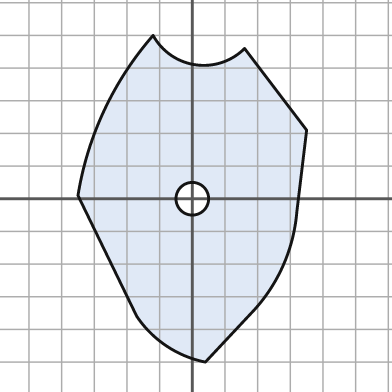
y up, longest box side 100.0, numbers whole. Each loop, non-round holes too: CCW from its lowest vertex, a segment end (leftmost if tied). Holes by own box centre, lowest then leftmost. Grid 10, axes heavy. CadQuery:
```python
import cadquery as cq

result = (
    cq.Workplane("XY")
    .moveTo(4.0, -50.0)
    .lineTo(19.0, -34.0)
    .threePointArc((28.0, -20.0), (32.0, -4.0))
    .lineTo(35.0, 21.0)
    .lineTo(16.0, 46.0)
    .threePointArc((1.0, 41.0), (-12.0, 50.0))
    .threePointArc((-27.0, 27.0), (-35.0, 1.0))
    .lineTo(-17.0, -36.0)
    .threePointArc((-8.0, -45.0), (4.0, -50.0))
    .close()
    .moveTo(0.0, 0.0)
    .circle(5.0)
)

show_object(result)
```